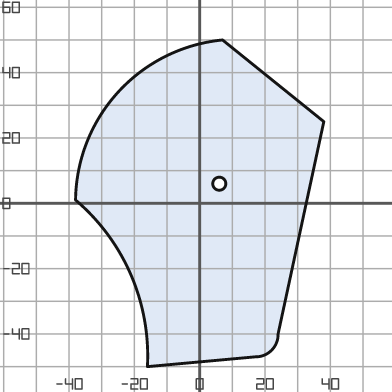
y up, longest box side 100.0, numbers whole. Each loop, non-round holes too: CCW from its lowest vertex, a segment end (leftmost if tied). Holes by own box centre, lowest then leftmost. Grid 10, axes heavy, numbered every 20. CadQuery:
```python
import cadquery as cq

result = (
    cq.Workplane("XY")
    .moveTo(-16.0, -50.0)
    .lineTo(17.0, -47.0)
    .threePointArc((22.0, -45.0), (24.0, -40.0))
    .lineTo(38.0, 25.0)
    .lineTo(7.0, 50.0)
    .threePointArc((-25.0, 34.0), (-38.0, 1.0))
    .threePointArc((-21.0, -22.0), (-16.0, -50.0))
    .close()
    .moveTo(6.0, 6.0)
    .circle(2.0)
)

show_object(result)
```